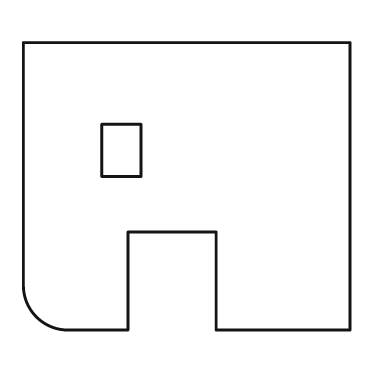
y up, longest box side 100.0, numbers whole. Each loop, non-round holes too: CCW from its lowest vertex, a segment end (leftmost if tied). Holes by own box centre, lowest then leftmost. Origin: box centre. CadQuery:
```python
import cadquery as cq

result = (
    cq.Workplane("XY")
    .moveTo(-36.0, -44.0)
    .lineTo(-18.0, -44.0)
    .lineTo(-18.0, -14.0)
    .lineTo(9.0, -14.0)
    .lineTo(9.0, -44.0)
    .lineTo(50.0, -44.0)
    .lineTo(50.0, 44.0)
    .lineTo(-50.0, 44.0)
    .lineTo(-50.0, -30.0)
    .threePointArc((-46.0, -40.0), (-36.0, -44.0))
    .close()
    .moveTo(-26.0, 3.0)
    .lineTo(-14.0, 3.0)
    .lineTo(-14.0, 19.0)
    .lineTo(-26.0, 19.0)
    .close()
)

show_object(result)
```